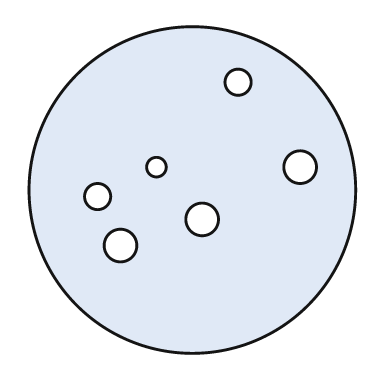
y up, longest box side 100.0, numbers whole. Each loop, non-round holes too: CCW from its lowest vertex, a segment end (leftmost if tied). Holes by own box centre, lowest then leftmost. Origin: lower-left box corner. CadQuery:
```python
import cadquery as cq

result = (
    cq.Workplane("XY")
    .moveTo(50.0, 50.0)
    .circle(50.0)
    .moveTo(28.0, 33.0)
    .circle(5.0)
    .moveTo(53.0, 41.0)
    .circle(5.0)
    .moveTo(21.0, 48.0)
    .circle(4.0)
    .moveTo(39.0, 57.0)
    .circle(3.0)
    .moveTo(83.0, 57.0)
    .circle(5.0)
    .moveTo(64.0, 83.0)
    .circle(4.0)
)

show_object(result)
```